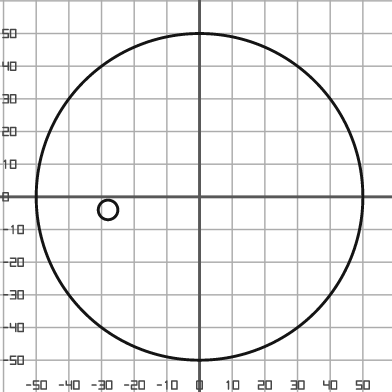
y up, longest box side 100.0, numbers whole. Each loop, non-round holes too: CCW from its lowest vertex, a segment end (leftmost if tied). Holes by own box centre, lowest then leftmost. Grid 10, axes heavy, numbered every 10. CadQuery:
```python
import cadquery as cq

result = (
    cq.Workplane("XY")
    .moveTo(0.0, 0.0)
    .circle(50.0)
    .moveTo(-28.0, -4.0)
    .circle(3.0)
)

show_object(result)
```